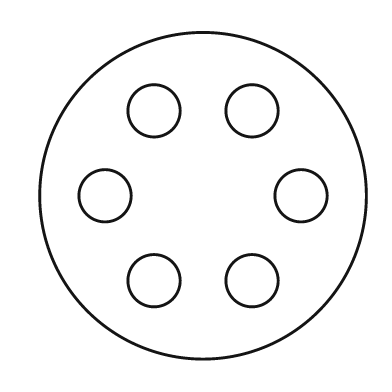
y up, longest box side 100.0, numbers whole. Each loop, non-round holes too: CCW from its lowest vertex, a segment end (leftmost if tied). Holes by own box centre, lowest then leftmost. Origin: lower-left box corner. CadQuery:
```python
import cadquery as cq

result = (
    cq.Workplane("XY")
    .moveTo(50.0, 50.0)
    .circle(50.0)
    .moveTo(35.0, 24.0)
    .circle(8.0)
    .moveTo(65.0, 24.0)
    .circle(8.0)
    .moveTo(20.0, 50.0)
    .circle(8.0)
    .moveTo(80.0, 50.0)
    .circle(8.0)
    .moveTo(35.0, 76.0)
    .circle(8.0)
    .moveTo(65.0, 76.0)
    .circle(8.0)
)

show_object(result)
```